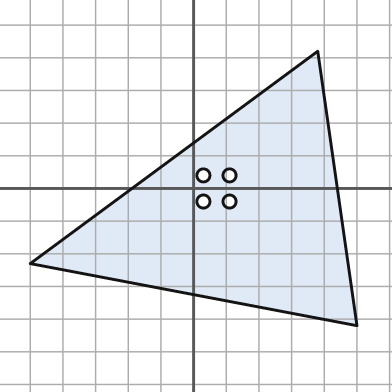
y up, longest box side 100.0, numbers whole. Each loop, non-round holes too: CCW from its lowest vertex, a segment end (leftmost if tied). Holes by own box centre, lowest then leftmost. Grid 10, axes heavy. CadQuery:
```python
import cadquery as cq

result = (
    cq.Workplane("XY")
    .moveTo(50.0, -42.0)
    .lineTo(38.0, 42.0)
    .lineTo(-50.0, -23.0)
    .close()
    .moveTo(3.0, -4.0)
    .circle(2.0)
    .moveTo(11.0, -4.0)
    .circle(2.0)
    .moveTo(3.0, 4.0)
    .circle(2.0)
    .moveTo(11.0, 4.0)
    .circle(2.0)
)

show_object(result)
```